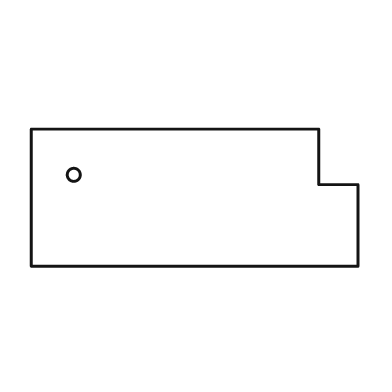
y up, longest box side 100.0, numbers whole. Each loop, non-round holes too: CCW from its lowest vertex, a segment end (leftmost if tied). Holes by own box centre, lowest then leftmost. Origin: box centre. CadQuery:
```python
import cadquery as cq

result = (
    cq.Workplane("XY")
    .moveTo(-50.0, -21.0)
    .lineTo(50.0, -21.0)
    .lineTo(50.0, 4.0)
    .lineTo(38.0, 4.0)
    .lineTo(38.0, 21.0)
    .lineTo(-50.0, 21.0)
    .close()
    .moveTo(-37.0, 7.0)
    .circle(2.0)
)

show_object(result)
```